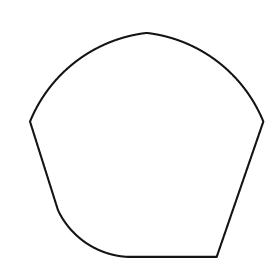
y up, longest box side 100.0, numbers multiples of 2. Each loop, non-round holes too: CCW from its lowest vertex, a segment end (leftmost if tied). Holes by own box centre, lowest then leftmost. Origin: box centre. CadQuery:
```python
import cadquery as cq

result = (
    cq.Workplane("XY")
    .moveTo(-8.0, -48.0)
    .lineTo(30.0, -48.0)
    .lineTo(50.0, 10.0)
    .threePointArc((30.0, 36.0), (0.0, 48.0))
    .threePointArc((-30.0, 36.0), (-50.0, 10.0))
    .lineTo(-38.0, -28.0)
    .threePointArc((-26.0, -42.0), (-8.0, -48.0))
    .close()
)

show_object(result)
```